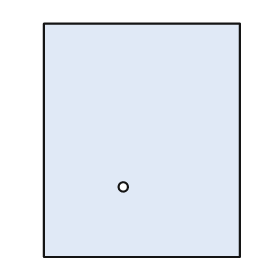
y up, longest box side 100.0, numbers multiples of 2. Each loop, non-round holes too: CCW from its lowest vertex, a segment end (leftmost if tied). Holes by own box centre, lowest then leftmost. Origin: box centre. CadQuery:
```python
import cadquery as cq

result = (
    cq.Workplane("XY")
    .moveTo(-42.0, -50.0)
    .lineTo(42.0, -50.0)
    .lineTo(42.0, 50.0)
    .lineTo(-42.0, 50.0)
    .close()
    .moveTo(-8.0, -20.0)
    .circle(2.0)
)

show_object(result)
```